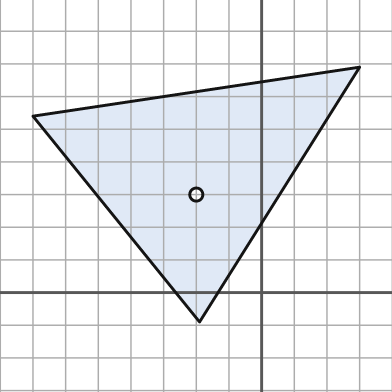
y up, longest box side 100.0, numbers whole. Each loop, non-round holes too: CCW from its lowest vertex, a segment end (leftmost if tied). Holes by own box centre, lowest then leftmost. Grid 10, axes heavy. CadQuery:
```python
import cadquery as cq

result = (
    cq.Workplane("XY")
    .moveTo(-19.0, -9.0)
    .lineTo(30.0, 69.0)
    .lineTo(-70.0, 54.0)
    .close()
    .moveTo(-20.0, 30.0)
    .circle(2.0)
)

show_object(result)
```